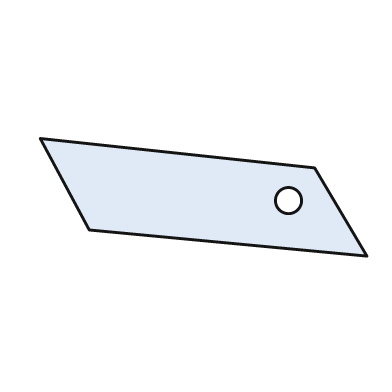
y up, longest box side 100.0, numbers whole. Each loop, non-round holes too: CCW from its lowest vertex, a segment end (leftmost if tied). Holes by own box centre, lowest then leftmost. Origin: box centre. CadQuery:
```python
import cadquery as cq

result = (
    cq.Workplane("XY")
    .moveTo(50.0, -18.0)
    .lineTo(34.0, 9.0)
    .lineTo(-50.0, 18.0)
    .lineTo(-35.0, -10.0)
    .close()
    .moveTo(26.0, -1.0)
    .circle(4.0)
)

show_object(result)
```